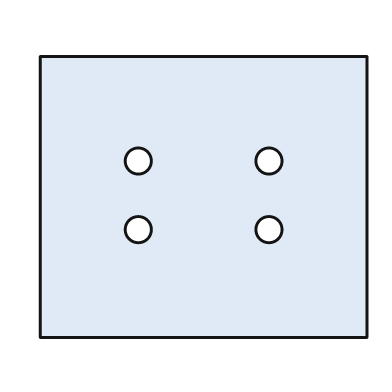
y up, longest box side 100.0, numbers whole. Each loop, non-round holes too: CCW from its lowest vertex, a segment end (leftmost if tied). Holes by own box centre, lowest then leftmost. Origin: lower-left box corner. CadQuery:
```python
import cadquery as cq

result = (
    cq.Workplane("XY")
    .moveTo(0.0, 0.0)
    .lineTo(100.0, 0.0)
    .lineTo(100.0, 86.0)
    .lineTo(0.0, 86.0)
    .close()
    .moveTo(30.0, 33.0)
    .circle(4.0)
    .moveTo(70.0, 33.0)
    .circle(4.0)
    .moveTo(30.0, 54.0)
    .circle(4.0)
    .moveTo(70.0, 54.0)
    .circle(4.0)
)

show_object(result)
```